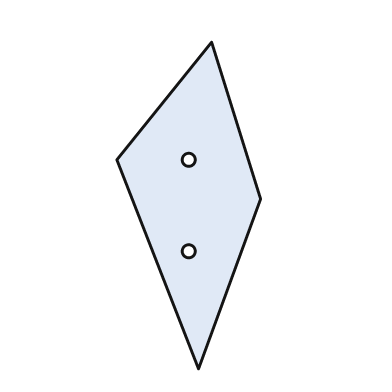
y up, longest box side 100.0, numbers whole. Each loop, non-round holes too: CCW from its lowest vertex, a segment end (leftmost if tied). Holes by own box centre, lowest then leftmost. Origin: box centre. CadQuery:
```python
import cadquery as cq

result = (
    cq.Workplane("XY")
    .moveTo(3.0, -50.0)
    .lineTo(22.0, 2.0)
    .lineTo(7.0, 50.0)
    .lineTo(-22.0, 14.0)
    .close()
    .moveTo(0.0, -14.0)
    .circle(2.0)
    .moveTo(0.0, 14.0)
    .circle(2.0)
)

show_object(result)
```